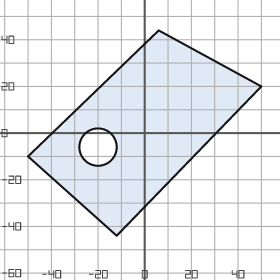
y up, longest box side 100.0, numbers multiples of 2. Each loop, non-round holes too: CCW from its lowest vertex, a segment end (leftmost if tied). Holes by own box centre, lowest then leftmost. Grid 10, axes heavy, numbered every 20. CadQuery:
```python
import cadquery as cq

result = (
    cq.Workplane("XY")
    .moveTo(-12.0, -44.0)
    .lineTo(50.0, 20.0)
    .lineTo(6.0, 44.0)
    .lineTo(-50.0, -10.0)
    .close()
    .moveTo(-20.0, -6.0)
    .circle(8.0)
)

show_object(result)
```